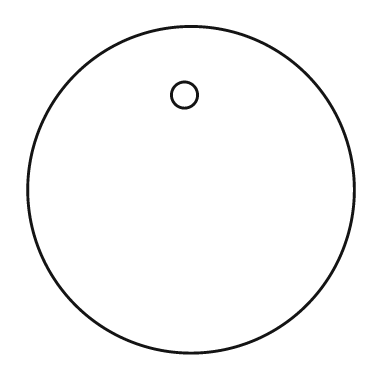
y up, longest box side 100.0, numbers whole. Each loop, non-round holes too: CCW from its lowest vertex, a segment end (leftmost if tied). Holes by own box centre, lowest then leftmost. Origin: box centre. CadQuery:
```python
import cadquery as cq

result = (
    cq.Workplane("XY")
    .moveTo(0.0, 0.0)
    .circle(50.0)
    .moveTo(-2.0, 29.0)
    .circle(4.0)
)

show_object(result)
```